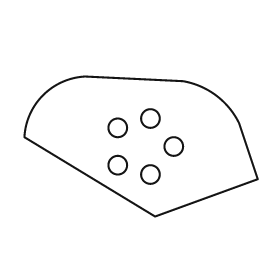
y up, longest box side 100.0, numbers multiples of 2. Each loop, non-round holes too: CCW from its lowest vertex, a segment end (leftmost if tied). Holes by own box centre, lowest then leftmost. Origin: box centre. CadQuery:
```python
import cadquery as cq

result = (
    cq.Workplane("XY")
    .moveTo(6.0, -30.0)
    .lineTo(50.0, -14.0)
    .lineTo(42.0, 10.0)
    .threePointArc((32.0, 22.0), (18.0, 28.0))
    .lineTo(-24.0, 30.0)
    .threePointArc((-42.0, 22.0), (-50.0, 4.0))
    .close()
    .moveTo(4.0, -12.0)
    .circle(4.0)
    .moveTo(-10.0, -8.0)
    .circle(4.0)
    .moveTo(14.0, 0.0)
    .circle(4.0)
    .moveTo(-10.0, 8.0)
    .circle(4.0)
    .moveTo(4.0, 12.0)
    .circle(4.0)
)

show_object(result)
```